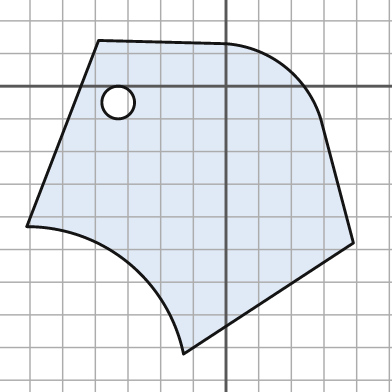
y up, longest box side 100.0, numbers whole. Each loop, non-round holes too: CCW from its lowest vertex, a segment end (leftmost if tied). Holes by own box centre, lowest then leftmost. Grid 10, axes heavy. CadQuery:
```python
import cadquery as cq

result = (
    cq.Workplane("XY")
    .moveTo(-13.0, -82.0)
    .lineTo(39.0, -48.0)
    .lineTo(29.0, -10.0)
    .threePointArc((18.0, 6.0), (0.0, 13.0))
    .lineTo(-39.0, 14.0)
    .lineTo(-61.0, -43.0)
    .threePointArc((-30.0, -54.0), (-13.0, -82.0))
    .close()
    .moveTo(-33.0, -5.0)
    .circle(5.0)
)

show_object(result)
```